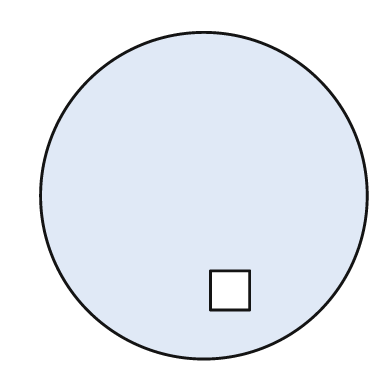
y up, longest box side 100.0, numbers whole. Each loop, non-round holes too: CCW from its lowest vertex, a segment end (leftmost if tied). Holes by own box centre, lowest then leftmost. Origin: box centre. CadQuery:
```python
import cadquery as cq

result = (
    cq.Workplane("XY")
    .moveTo(0.0, 0.0)
    .circle(50.0)
    .moveTo(2.0, -35.0)
    .lineTo(14.0, -35.0)
    .lineTo(14.0, -23.0)
    .lineTo(2.0, -23.0)
    .close()
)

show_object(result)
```